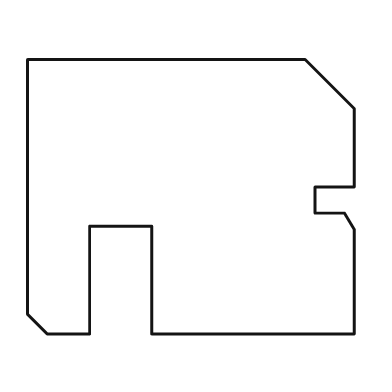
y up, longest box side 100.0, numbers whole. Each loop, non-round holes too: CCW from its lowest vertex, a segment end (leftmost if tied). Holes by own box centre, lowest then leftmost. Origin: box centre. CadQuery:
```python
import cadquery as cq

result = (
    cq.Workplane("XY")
    .moveTo(-44.0, -42.0)
    .lineTo(-31.0, -42.0)
    .lineTo(-31.0, -9.0)
    .lineTo(-12.0, -9.0)
    .lineTo(-12.0, -42.0)
    .lineTo(50.0, -42.0)
    .lineTo(50.0, -10.0)
    .lineTo(47.0, -5.0)
    .lineTo(38.0, -5.0)
    .lineTo(38.0, 3.0)
    .lineTo(50.0, 3.0)
    .lineTo(50.0, 27.0)
    .lineTo(35.0, 42.0)
    .lineTo(-50.0, 42.0)
    .lineTo(-50.0, -36.0)
    .close()
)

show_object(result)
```